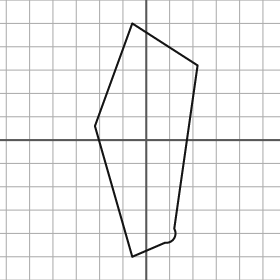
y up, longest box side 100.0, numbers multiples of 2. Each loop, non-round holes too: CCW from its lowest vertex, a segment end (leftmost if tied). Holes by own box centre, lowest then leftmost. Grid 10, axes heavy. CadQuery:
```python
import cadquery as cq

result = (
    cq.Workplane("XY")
    .moveTo(-6.0, -50.0)
    .lineTo(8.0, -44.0)
    .threePointArc((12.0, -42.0), (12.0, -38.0))
    .lineTo(22.0, 32.0)
    .lineTo(-6.0, 50.0)
    .lineTo(-22.0, 6.0)
    .close()
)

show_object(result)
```